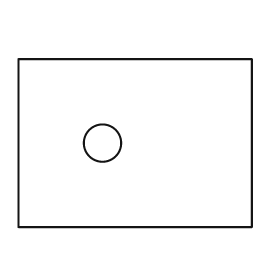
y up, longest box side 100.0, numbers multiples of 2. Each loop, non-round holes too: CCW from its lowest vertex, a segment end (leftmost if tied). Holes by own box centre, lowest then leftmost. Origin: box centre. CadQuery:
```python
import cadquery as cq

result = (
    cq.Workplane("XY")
    .moveTo(-50.0, -36.0)
    .lineTo(50.0, -36.0)
    .lineTo(50.0, 36.0)
    .lineTo(-50.0, 36.0)
    .close()
    .moveTo(-14.0, 0.0)
    .circle(8.0)
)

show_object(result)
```